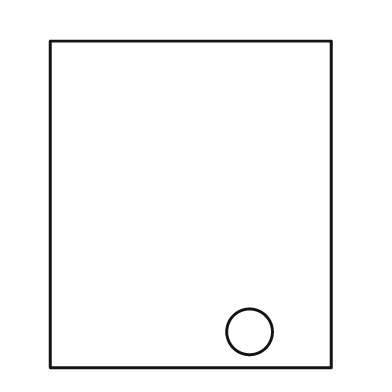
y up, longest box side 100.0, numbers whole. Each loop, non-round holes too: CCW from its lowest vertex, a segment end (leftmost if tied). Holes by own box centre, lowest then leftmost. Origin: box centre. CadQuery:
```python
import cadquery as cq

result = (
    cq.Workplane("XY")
    .moveTo(-43.0, -50.0)
    .lineTo(43.0, -50.0)
    .lineTo(43.0, 50.0)
    .lineTo(-43.0, 50.0)
    .close()
    .moveTo(18.0, -39.0)
    .circle(7.0)
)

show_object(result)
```